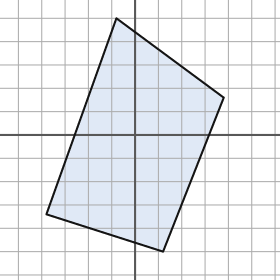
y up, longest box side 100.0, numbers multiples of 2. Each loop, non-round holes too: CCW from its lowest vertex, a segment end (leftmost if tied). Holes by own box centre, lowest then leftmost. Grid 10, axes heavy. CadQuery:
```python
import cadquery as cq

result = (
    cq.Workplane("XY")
    .moveTo(12.0, -50.0)
    .lineTo(38.0, 16.0)
    .lineTo(-8.0, 50.0)
    .lineTo(-38.0, -34.0)
    .close()
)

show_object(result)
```